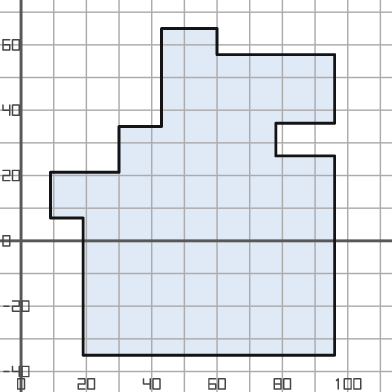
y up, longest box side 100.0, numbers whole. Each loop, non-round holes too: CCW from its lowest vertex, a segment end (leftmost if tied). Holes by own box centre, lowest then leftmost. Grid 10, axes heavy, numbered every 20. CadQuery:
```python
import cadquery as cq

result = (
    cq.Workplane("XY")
    .moveTo(19.0, -35.0)
    .lineTo(96.0, -35.0)
    .lineTo(96.0, 26.0)
    .lineTo(78.0, 26.0)
    .lineTo(78.0, 36.0)
    .lineTo(96.0, 36.0)
    .lineTo(96.0, 57.0)
    .lineTo(60.0, 57.0)
    .lineTo(60.0, 65.0)
    .lineTo(43.0, 65.0)
    .lineTo(43.0, 35.0)
    .lineTo(30.0, 35.0)
    .lineTo(30.0, 21.0)
    .lineTo(9.0, 21.0)
    .lineTo(9.0, 7.0)
    .lineTo(19.0, 7.0)
    .close()
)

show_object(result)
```